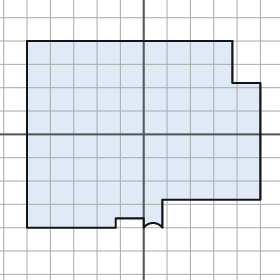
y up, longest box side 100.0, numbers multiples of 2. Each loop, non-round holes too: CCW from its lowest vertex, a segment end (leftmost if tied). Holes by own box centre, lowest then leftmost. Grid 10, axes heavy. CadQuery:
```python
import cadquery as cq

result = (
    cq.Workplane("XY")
    .moveTo(-50.0, -40.0)
    .lineTo(-12.0, -40.0)
    .lineTo(-12.0, -36.0)
    .lineTo(0.0, -36.0)
    .lineTo(0.0, -40.0)
    .threePointArc((4.0, -38.0), (8.0, -40.0))
    .lineTo(8.0, -28.0)
    .lineTo(50.0, -28.0)
    .lineTo(50.0, 22.0)
    .lineTo(38.0, 22.0)
    .lineTo(38.0, 40.0)
    .lineTo(-50.0, 40.0)
    .close()
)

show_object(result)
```